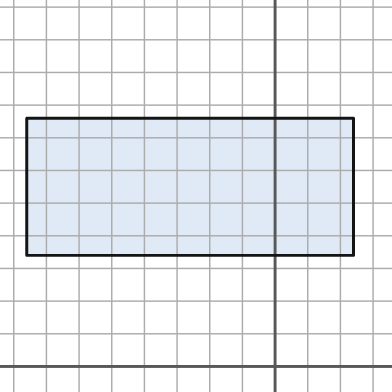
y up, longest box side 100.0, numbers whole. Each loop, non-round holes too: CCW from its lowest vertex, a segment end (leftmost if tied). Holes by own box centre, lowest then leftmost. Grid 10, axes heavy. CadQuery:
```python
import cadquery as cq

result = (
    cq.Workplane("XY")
    .moveTo(-76.0, 34.0)
    .lineTo(24.0, 34.0)
    .lineTo(24.0, 76.0)
    .lineTo(-76.0, 76.0)
    .close()
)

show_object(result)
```